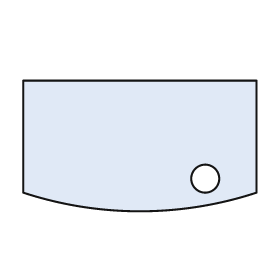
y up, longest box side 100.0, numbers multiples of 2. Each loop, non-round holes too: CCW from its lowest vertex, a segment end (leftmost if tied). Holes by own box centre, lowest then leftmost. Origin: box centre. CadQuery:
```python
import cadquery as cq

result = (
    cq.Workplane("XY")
    .moveTo(-50.0, -20.0)
    .threePointArc((0.0, -28.0), (50.0, -20.0))
    .lineTo(50.0, 28.0)
    .lineTo(-50.0, 28.0)
    .close()
    .moveTo(28.0, -14.0)
    .circle(6.0)
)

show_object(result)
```